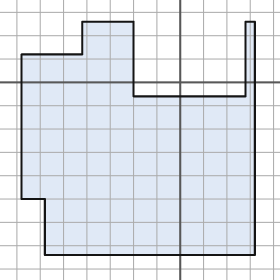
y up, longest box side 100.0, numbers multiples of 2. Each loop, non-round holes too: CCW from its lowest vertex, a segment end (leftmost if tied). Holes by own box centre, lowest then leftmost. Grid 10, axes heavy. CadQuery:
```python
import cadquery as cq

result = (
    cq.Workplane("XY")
    .moveTo(-58.0, -74.0)
    .lineTo(32.0, -74.0)
    .lineTo(32.0, 26.0)
    .lineTo(28.0, 26.0)
    .lineTo(28.0, -6.0)
    .lineTo(-20.0, -6.0)
    .lineTo(-20.0, 26.0)
    .lineTo(-42.0, 26.0)
    .lineTo(-42.0, 12.0)
    .lineTo(-68.0, 12.0)
    .lineTo(-68.0, -50.0)
    .lineTo(-58.0, -50.0)
    .close()
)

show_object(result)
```